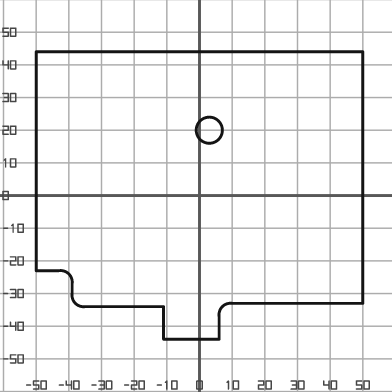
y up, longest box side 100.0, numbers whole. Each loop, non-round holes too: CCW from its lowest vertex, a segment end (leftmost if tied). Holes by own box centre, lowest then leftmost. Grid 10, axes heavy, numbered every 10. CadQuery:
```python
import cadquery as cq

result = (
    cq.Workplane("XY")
    .moveTo(-11.0, -44.0)
    .lineTo(6.0, -44.0)
    .lineTo(6.0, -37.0)
    .threePointArc((7.0, -34.0), (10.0, -33.0))
    .lineTo(50.0, -33.0)
    .lineTo(50.0, 44.0)
    .lineTo(-50.0, 44.0)
    .lineTo(-50.0, -23.0)
    .lineTo(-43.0, -23.0)
    .threePointArc((-40.0, -24.0), (-39.0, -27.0))
    .lineTo(-39.0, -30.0)
    .threePointArc((-38.0, -33.0), (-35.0, -34.0))
    .lineTo(-11.0, -34.0)
    .close()
    .moveTo(3.0, 20.0)
    .circle(4.0)
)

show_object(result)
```